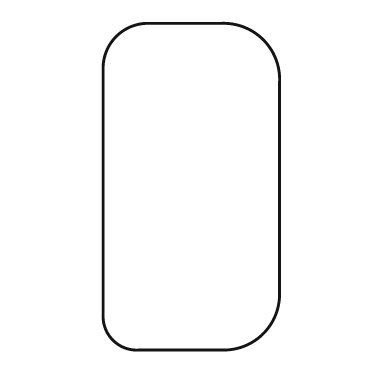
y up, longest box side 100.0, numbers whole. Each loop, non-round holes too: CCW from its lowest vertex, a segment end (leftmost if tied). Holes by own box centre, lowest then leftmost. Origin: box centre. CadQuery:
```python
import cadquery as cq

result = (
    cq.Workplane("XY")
    .moveTo(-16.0, -50.0)
    .lineTo(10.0, -50.0)
    .threePointArc((22.0, -45.0), (27.0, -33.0))
    .lineTo(27.0, 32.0)
    .threePointArc((22.0, 45.0), (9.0, 50.0))
    .lineTo(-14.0, 50.0)
    .threePointArc((-23.0, 46.0), (-27.0, 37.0))
    .lineTo(-27.0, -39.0)
    .threePointArc((-24.0, -47.0), (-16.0, -50.0))
    .close()
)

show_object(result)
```